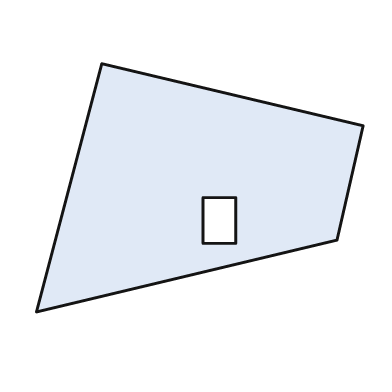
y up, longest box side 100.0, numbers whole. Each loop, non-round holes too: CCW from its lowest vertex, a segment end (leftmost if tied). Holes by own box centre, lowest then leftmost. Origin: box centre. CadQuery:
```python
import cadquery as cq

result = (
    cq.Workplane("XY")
    .moveTo(-50.0, -38.0)
    .lineTo(42.0, -16.0)
    .lineTo(50.0, 19.0)
    .lineTo(-30.0, 38.0)
    .close()
    .moveTo(1.0, -17.0)
    .lineTo(11.0, -17.0)
    .lineTo(11.0, -3.0)
    .lineTo(1.0, -3.0)
    .close()
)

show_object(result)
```